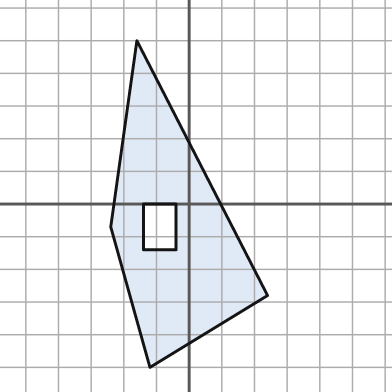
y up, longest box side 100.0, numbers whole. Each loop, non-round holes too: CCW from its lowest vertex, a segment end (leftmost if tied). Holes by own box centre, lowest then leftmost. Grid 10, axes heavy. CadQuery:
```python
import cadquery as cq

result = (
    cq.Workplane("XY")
    .moveTo(-12.0, -50.0)
    .lineTo(24.0, -28.0)
    .lineTo(-16.0, 50.0)
    .lineTo(-24.0, -7.0)
    .close()
    .moveTo(-14.0, -14.0)
    .lineTo(-4.0, -14.0)
    .lineTo(-4.0, 0.0)
    .lineTo(-14.0, 0.0)
    .close()
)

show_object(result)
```